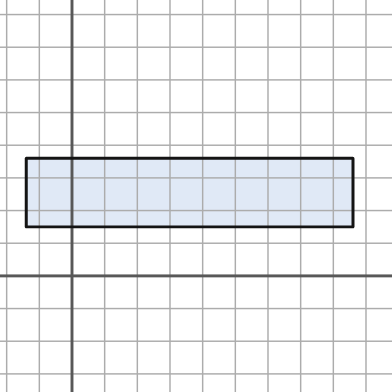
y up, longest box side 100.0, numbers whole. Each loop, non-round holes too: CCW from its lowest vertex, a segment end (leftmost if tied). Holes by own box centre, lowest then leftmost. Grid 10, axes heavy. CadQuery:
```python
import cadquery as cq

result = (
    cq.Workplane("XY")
    .moveTo(-14.0, 15.0)
    .lineTo(86.0, 15.0)
    .lineTo(86.0, 36.0)
    .lineTo(-14.0, 36.0)
    .close()
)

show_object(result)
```